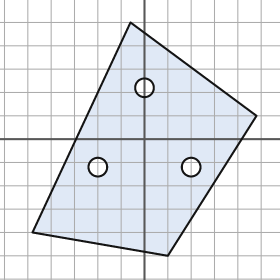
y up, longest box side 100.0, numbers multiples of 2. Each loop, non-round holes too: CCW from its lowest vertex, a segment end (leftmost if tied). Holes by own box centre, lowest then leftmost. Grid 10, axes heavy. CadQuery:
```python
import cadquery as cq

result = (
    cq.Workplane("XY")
    .moveTo(10.0, -50.0)
    .lineTo(48.0, 10.0)
    .lineTo(-6.0, 50.0)
    .lineTo(-48.0, -40.0)
    .close()
    .moveTo(-20.0, -12.0)
    .circle(4.0)
    .moveTo(20.0, -12.0)
    .circle(4.0)
    .moveTo(0.0, 22.0)
    .circle(4.0)
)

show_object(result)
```